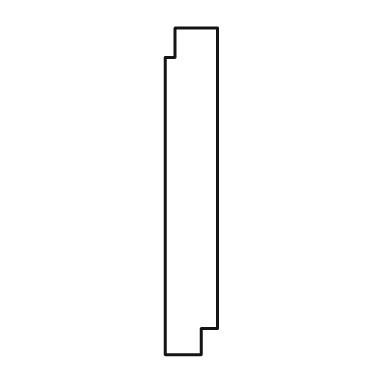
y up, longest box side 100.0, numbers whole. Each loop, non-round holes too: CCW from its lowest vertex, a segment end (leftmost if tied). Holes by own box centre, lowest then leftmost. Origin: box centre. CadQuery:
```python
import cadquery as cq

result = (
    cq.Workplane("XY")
    .moveTo(-8.0, -50.0)
    .lineTo(3.0, -50.0)
    .lineTo(3.0, -42.0)
    .lineTo(8.0, -42.0)
    .lineTo(8.0, 50.0)
    .lineTo(-5.0, 50.0)
    .lineTo(-5.0, 41.0)
    .lineTo(-8.0, 41.0)
    .close()
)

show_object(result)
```